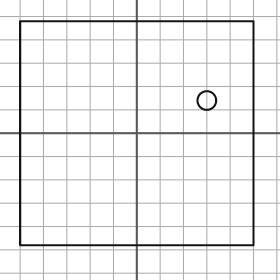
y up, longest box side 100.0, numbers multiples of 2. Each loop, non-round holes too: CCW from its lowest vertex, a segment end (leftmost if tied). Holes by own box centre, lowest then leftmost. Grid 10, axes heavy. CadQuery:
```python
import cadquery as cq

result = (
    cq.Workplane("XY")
    .moveTo(-50.0, -48.0)
    .lineTo(50.0, -48.0)
    .lineTo(50.0, 48.0)
    .lineTo(-50.0, 48.0)
    .close()
    .moveTo(30.0, 14.0)
    .circle(4.0)
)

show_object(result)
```